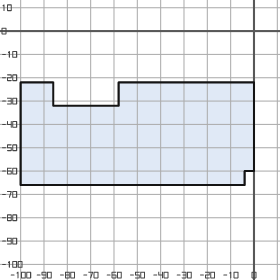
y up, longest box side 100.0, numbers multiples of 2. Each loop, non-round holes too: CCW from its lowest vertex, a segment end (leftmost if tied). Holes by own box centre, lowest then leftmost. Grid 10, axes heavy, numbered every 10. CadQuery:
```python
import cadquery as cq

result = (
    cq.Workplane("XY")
    .moveTo(-100.0, -66.0)
    .lineTo(-4.0, -66.0)
    .lineTo(-4.0, -60.0)
    .lineTo(0.0, -60.0)
    .lineTo(0.0, -22.0)
    .lineTo(-58.0, -22.0)
    .lineTo(-58.0, -32.0)
    .lineTo(-86.0, -32.0)
    .lineTo(-86.0, -22.0)
    .lineTo(-100.0, -22.0)
    .close()
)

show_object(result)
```